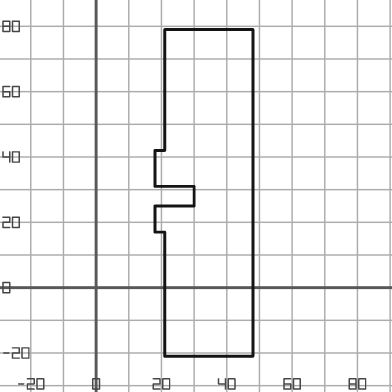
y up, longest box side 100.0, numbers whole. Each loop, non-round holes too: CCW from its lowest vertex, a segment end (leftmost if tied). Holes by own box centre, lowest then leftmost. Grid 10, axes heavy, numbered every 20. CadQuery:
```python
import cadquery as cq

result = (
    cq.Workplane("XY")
    .moveTo(21.0, -21.0)
    .lineTo(48.0, -21.0)
    .lineTo(48.0, 79.0)
    .lineTo(21.0, 79.0)
    .lineTo(21.0, 42.0)
    .lineTo(18.0, 42.0)
    .lineTo(18.0, 31.0)
    .lineTo(30.0, 31.0)
    .lineTo(30.0, 25.0)
    .lineTo(18.0, 25.0)
    .lineTo(18.0, 17.0)
    .lineTo(21.0, 17.0)
    .close()
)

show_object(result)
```